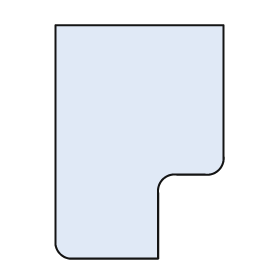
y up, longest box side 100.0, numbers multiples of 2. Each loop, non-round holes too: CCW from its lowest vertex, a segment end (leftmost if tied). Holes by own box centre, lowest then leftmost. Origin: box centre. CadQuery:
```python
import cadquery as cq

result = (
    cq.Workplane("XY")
    .moveTo(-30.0, -50.0)
    .lineTo(8.0, -50.0)
    .lineTo(8.0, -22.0)
    .threePointArc((10.0, -16.0), (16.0, -14.0))
    .lineTo(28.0, -14.0)
    .threePointArc((34.0, -12.0), (36.0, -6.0))
    .lineTo(36.0, 50.0)
    .lineTo(-36.0, 50.0)
    .lineTo(-36.0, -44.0)
    .threePointArc((-34.0, -48.0), (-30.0, -50.0))
    .close()
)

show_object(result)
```